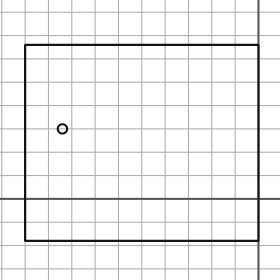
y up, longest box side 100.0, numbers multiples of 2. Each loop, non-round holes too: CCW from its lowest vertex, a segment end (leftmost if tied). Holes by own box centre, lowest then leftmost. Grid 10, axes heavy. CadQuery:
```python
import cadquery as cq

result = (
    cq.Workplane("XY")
    .moveTo(-100.0, -18.0)
    .lineTo(0.0, -18.0)
    .lineTo(0.0, 66.0)
    .lineTo(-100.0, 66.0)
    .close()
    .moveTo(-84.0, 30.0)
    .circle(2.0)
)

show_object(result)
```